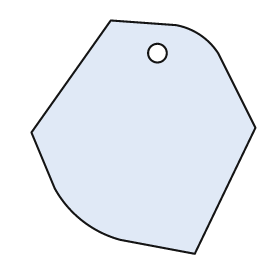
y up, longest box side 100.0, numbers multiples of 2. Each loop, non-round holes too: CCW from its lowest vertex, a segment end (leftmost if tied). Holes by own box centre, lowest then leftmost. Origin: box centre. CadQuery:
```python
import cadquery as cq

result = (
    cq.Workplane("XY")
    .moveTo(22.0, -50.0)
    .lineTo(48.0, 4.0)
    .lineTo(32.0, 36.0)
    .threePointArc((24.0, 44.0), (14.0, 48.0))
    .lineTo(-14.0, 50.0)
    .lineTo(-48.0, 2.0)
    .lineTo(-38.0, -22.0)
    .threePointArc((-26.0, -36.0), (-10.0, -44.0))
    .close()
    .moveTo(6.0, 36.0)
    .circle(4.0)
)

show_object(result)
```